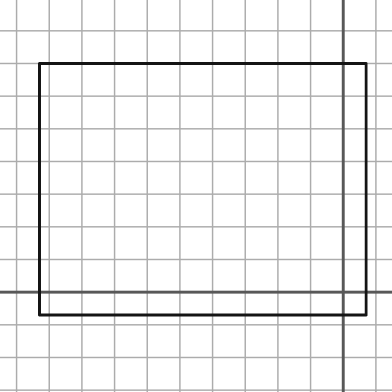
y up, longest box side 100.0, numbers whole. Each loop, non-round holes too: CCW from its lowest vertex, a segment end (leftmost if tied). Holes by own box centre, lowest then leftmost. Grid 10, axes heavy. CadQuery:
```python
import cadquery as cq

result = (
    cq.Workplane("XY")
    .moveTo(-93.0, -7.0)
    .lineTo(7.0, -7.0)
    .lineTo(7.0, 70.0)
    .lineTo(-93.0, 70.0)
    .close()
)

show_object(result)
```